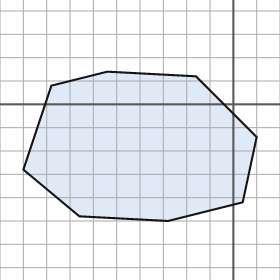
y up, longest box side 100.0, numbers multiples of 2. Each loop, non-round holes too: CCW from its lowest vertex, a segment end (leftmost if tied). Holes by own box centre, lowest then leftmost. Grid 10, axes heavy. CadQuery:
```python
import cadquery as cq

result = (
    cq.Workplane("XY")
    .moveTo(-28.0, -50.0)
    .lineTo(4.0, -42.0)
    .lineTo(10.0, -14.0)
    .lineTo(-16.0, 12.0)
    .lineTo(-54.0, 14.0)
    .lineTo(-78.0, 8.0)
    .lineTo(-90.0, -28.0)
    .lineTo(-66.0, -48.0)
    .close()
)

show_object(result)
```